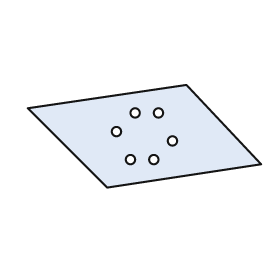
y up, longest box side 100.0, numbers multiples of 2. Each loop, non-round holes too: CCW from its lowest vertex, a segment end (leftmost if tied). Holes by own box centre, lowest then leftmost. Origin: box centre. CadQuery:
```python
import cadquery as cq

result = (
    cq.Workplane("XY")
    .moveTo(-16.0, -22.0)
    .lineTo(50.0, -12.0)
    .lineTo(18.0, 22.0)
    .lineTo(-50.0, 12.0)
    .close()
    .moveTo(-6.0, -10.0)
    .circle(2.0)
    .moveTo(4.0, -10.0)
    .circle(2.0)
    .moveTo(12.0, -2.0)
    .circle(2.0)
    .moveTo(-12.0, 2.0)
    .circle(2.0)
    .moveTo(-4.0, 10.0)
    .circle(2.0)
    .moveTo(6.0, 10.0)
    .circle(2.0)
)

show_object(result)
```